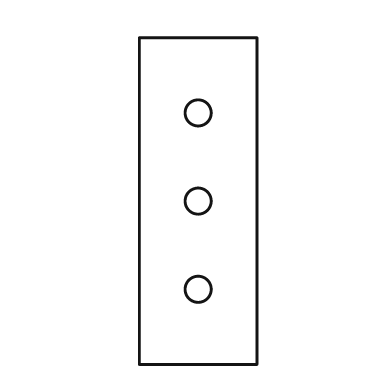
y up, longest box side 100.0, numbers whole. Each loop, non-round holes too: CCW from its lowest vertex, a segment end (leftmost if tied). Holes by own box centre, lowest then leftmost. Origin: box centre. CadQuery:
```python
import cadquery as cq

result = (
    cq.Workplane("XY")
    .moveTo(-18.0, -50.0)
    .lineTo(18.0, -50.0)
    .lineTo(18.0, 50.0)
    .lineTo(-18.0, 50.0)
    .close()
    .moveTo(0.0, -27.0)
    .circle(4.0)
    .moveTo(0.0, 0.0)
    .circle(4.0)
    .moveTo(0.0, 27.0)
    .circle(4.0)
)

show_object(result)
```